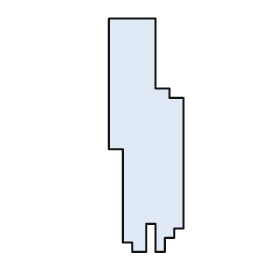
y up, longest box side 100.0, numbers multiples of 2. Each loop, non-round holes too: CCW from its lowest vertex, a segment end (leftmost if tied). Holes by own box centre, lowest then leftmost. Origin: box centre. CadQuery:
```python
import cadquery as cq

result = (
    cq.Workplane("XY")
    .moveTo(-6.0, -50.0)
    .lineTo(0.0, -50.0)
    .lineTo(0.0, -38.0)
    .lineTo(4.0, -38.0)
    .lineTo(4.0, -50.0)
    .lineTo(8.0, -50.0)
    .lineTo(8.0, -44.0)
    .lineTo(12.0, -44.0)
    .lineTo(12.0, -40.0)
    .lineTo(16.0, -40.0)
    .lineTo(16.0, 16.0)
    .lineTo(10.0, 16.0)
    .lineTo(10.0, 20.0)
    .lineTo(4.0, 20.0)
    .lineTo(4.0, 50.0)
    .lineTo(-16.0, 50.0)
    .lineTo(-16.0, -6.0)
    .lineTo(-10.0, -6.0)
    .lineTo(-10.0, -46.0)
    .lineTo(-6.0, -46.0)
    .close()
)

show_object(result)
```